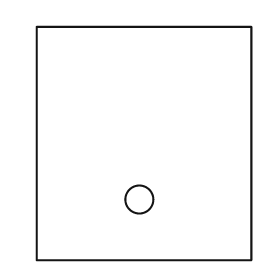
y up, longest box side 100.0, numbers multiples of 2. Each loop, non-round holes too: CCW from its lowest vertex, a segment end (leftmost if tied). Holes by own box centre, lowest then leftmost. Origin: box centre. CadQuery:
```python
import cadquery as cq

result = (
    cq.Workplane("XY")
    .moveTo(-46.0, -50.0)
    .lineTo(46.0, -50.0)
    .lineTo(46.0, 50.0)
    .lineTo(-46.0, 50.0)
    .close()
    .moveTo(-2.0, -24.0)
    .circle(6.0)
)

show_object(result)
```